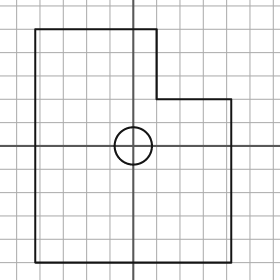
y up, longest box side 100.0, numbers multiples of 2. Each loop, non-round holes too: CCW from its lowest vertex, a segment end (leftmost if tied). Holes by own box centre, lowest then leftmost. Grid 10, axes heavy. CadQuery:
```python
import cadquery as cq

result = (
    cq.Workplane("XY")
    .moveTo(-42.0, -50.0)
    .lineTo(42.0, -50.0)
    .lineTo(42.0, 20.0)
    .lineTo(10.0, 20.0)
    .lineTo(10.0, 50.0)
    .lineTo(-42.0, 50.0)
    .close()
    .moveTo(0.0, 0.0)
    .circle(8.0)
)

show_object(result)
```